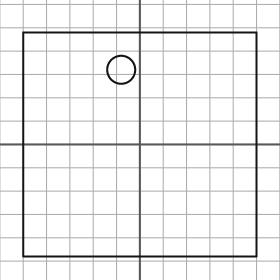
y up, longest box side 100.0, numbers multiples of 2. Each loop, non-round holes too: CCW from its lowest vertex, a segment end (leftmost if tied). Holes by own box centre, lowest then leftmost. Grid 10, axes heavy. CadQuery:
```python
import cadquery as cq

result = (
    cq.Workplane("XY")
    .moveTo(-50.0, -48.0)
    .lineTo(50.0, -48.0)
    .lineTo(50.0, 48.0)
    .lineTo(-50.0, 48.0)
    .close()
    .moveTo(-8.0, 32.0)
    .circle(6.0)
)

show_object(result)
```